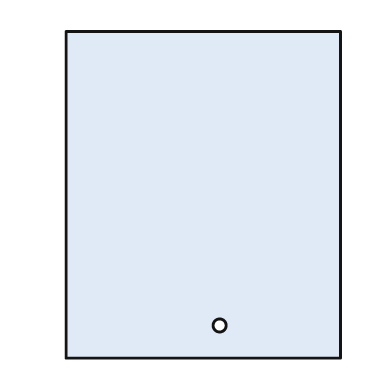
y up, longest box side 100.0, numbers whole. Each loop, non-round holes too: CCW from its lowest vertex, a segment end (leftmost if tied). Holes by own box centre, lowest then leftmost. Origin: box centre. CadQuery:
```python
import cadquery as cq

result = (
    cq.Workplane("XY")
    .moveTo(-42.0, -50.0)
    .lineTo(42.0, -50.0)
    .lineTo(42.0, 50.0)
    .lineTo(-42.0, 50.0)
    .close()
    .moveTo(5.0, -40.0)
    .circle(2.0)
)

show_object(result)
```